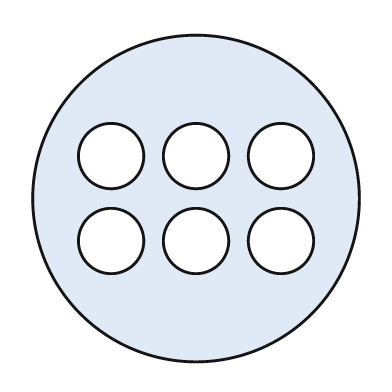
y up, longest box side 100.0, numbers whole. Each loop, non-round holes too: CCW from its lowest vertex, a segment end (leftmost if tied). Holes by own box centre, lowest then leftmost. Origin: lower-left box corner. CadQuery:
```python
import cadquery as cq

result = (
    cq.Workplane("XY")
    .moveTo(50.0, 50.0)
    .circle(50.0)
    .moveTo(24.0, 37.0)
    .circle(10.0)
    .moveTo(50.0, 37.0)
    .circle(10.0)
    .moveTo(76.0, 37.0)
    .circle(10.0)
    .moveTo(24.0, 63.0)
    .circle(10.0)
    .moveTo(50.0, 63.0)
    .circle(10.0)
    .moveTo(76.0, 63.0)
    .circle(10.0)
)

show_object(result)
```